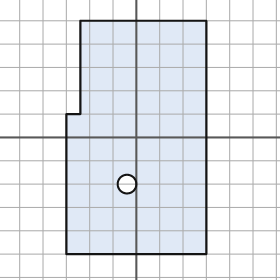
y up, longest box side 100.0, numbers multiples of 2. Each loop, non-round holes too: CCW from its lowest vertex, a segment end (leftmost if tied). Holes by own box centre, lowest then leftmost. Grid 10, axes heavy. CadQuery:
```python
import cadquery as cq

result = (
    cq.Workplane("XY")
    .moveTo(-30.0, -50.0)
    .lineTo(30.0, -50.0)
    .lineTo(30.0, 50.0)
    .lineTo(-24.0, 50.0)
    .lineTo(-24.0, 10.0)
    .lineTo(-30.0, 10.0)
    .close()
    .moveTo(-4.0, -20.0)
    .circle(4.0)
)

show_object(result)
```